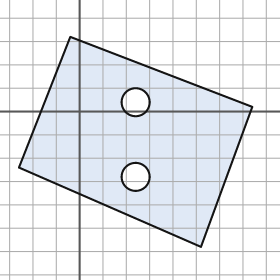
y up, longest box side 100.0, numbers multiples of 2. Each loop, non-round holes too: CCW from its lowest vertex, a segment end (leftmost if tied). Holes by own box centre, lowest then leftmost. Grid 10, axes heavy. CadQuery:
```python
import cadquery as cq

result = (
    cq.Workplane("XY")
    .moveTo(52.0, -58.0)
    .lineTo(74.0, 2.0)
    .lineTo(-4.0, 32.0)
    .lineTo(-26.0, -24.0)
    .close()
    .moveTo(24.0, -28.0)
    .circle(6.0)
    .moveTo(24.0, 4.0)
    .circle(6.0)
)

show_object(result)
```